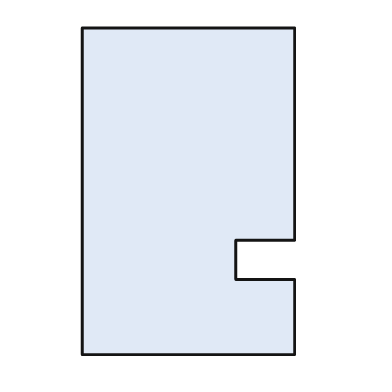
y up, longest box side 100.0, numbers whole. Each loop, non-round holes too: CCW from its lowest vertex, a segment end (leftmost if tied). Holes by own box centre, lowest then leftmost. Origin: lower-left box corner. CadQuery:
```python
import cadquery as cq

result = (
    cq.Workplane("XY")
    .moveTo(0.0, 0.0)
    .lineTo(65.0, 0.0)
    .lineTo(65.0, 23.0)
    .lineTo(47.0, 23.0)
    .lineTo(47.0, 35.0)
    .lineTo(65.0, 35.0)
    .lineTo(65.0, 100.0)
    .lineTo(0.0, 100.0)
    .close()
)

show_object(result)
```